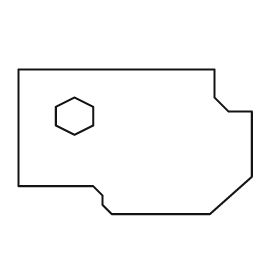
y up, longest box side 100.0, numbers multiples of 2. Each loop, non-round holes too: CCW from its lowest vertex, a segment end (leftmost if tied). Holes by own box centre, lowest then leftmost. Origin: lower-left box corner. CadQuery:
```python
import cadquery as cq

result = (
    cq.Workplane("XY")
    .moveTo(40.0, 0.0)
    .lineTo(82.0, 0.0)
    .lineTo(100.0, 16.0)
    .lineTo(100.0, 44.0)
    .lineTo(90.0, 44.0)
    .lineTo(84.0, 50.0)
    .lineTo(84.0, 62.0)
    .lineTo(0.0, 62.0)
    .lineTo(0.0, 12.0)
    .lineTo(32.0, 12.0)
    .lineTo(36.0, 8.0)
    .lineTo(36.0, 4.0)
    .close()
    .moveTo(24.0, 34.0)
    .lineTo(32.0, 38.0)
    .lineTo(32.0, 46.0)
    .lineTo(24.0, 50.0)
    .lineTo(16.0, 46.0)
    .lineTo(16.0, 38.0)
    .close()
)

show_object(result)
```